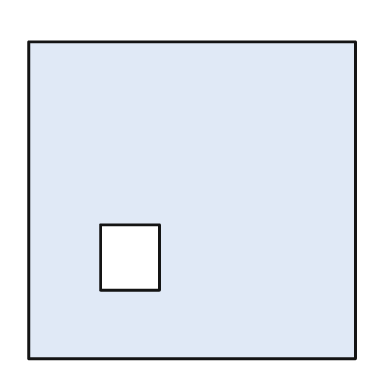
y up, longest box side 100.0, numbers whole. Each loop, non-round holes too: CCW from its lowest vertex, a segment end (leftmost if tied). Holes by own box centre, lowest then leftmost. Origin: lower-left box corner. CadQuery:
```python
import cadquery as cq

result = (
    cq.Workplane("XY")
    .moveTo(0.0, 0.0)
    .lineTo(100.0, 0.0)
    .lineTo(100.0, 97.0)
    .lineTo(0.0, 97.0)
    .close()
    .moveTo(22.0, 21.0)
    .lineTo(40.0, 21.0)
    .lineTo(40.0, 41.0)
    .lineTo(22.0, 41.0)
    .close()
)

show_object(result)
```